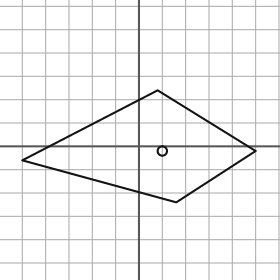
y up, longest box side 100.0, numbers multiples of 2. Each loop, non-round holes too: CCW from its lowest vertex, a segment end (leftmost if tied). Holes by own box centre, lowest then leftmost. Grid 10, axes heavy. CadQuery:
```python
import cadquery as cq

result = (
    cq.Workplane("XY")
    .moveTo(16.0, -24.0)
    .lineTo(50.0, -2.0)
    .lineTo(8.0, 24.0)
    .lineTo(-50.0, -6.0)
    .close()
    .moveTo(10.0, -2.0)
    .circle(2.0)
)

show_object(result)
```